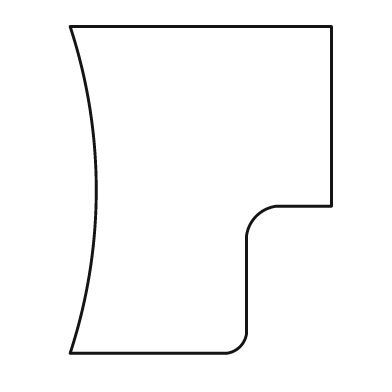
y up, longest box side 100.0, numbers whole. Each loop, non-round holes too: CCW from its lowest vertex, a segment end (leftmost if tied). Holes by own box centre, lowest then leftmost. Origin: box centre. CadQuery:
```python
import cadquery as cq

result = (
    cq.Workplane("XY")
    .moveTo(-40.0, -50.0)
    .lineTo(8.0, -50.0)
    .threePointArc((12.0, -48.0), (14.0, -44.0))
    .lineTo(14.0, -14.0)
    .threePointArc((17.0, -8.0), (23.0, -5.0))
    .lineTo(40.0, -5.0)
    .lineTo(40.0, 50.0)
    .lineTo(-40.0, 50.0)
    .threePointArc((-32.0, 0.0), (-40.0, -50.0))
    .close()
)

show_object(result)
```